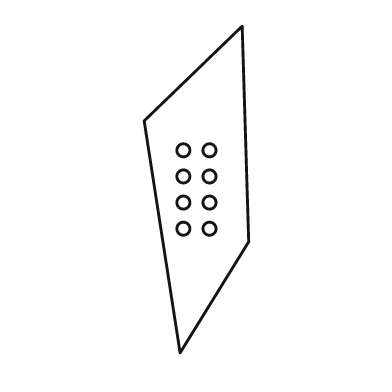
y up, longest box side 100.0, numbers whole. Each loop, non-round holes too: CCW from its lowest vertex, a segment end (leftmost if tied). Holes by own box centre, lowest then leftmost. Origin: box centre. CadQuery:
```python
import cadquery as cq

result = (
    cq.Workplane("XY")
    .moveTo(-5.0, -50.0)
    .lineTo(16.0, -16.0)
    .lineTo(14.0, 50.0)
    .lineTo(-16.0, 21.0)
    .close()
    .moveTo(-4.0, -12.0)
    .circle(2.0)
    .moveTo(4.0, -12.0)
    .circle(2.0)
    .moveTo(-4.0, -4.0)
    .circle(2.0)
    .moveTo(4.0, -4.0)
    .circle(2.0)
    .moveTo(-4.0, 4.0)
    .circle(2.0)
    .moveTo(4.0, 4.0)
    .circle(2.0)
    .moveTo(-4.0, 12.0)
    .circle(2.0)
    .moveTo(4.0, 12.0)
    .circle(2.0)
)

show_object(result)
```